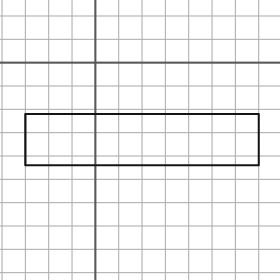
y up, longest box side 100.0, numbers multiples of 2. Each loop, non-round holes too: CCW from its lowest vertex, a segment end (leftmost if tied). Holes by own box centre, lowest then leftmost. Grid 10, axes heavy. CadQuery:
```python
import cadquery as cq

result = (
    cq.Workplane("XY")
    .moveTo(-30.0, -44.0)
    .lineTo(70.0, -44.0)
    .lineTo(70.0, -22.0)
    .lineTo(-30.0, -22.0)
    .close()
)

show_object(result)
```